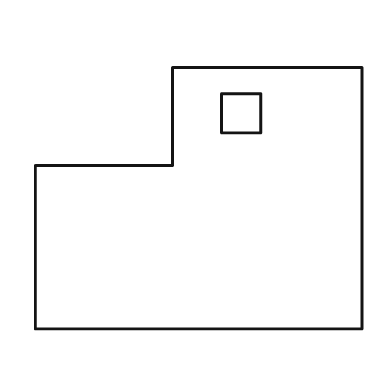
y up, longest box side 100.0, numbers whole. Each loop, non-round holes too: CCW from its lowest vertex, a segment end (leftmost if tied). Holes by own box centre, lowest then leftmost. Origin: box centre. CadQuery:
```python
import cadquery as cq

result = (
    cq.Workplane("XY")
    .moveTo(-50.0, -40.0)
    .lineTo(50.0, -40.0)
    .lineTo(50.0, 40.0)
    .lineTo(-8.0, 40.0)
    .lineTo(-8.0, 10.0)
    .lineTo(-50.0, 10.0)
    .close()
    .moveTo(7.0, 20.0)
    .lineTo(19.0, 20.0)
    .lineTo(19.0, 32.0)
    .lineTo(7.0, 32.0)
    .close()
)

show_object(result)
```